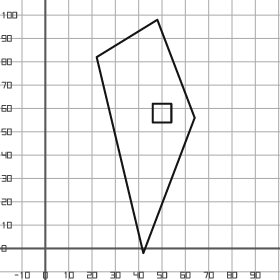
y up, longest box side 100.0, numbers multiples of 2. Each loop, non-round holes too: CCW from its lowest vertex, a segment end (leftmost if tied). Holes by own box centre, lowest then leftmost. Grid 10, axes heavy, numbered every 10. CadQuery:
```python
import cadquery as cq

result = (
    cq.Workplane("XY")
    .moveTo(42.0, -2.0)
    .lineTo(64.0, 56.0)
    .lineTo(48.0, 98.0)
    .lineTo(22.0, 82.0)
    .close()
    .moveTo(46.0, 54.0)
    .lineTo(54.0, 54.0)
    .lineTo(54.0, 62.0)
    .lineTo(46.0, 62.0)
    .close()
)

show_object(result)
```